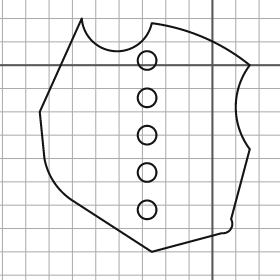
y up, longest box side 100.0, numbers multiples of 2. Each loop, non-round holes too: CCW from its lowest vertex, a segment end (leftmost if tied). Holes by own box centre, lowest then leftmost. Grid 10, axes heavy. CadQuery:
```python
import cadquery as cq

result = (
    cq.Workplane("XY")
    .moveTo(-26.0, -80.0)
    .lineTo(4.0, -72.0)
    .threePointArc((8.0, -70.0), (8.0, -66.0))
    .lineTo(16.0, -36.0)
    .threePointArc((10.0, -18.0), (16.0, 0.0))
    .threePointArc((-4.0, 12.0), (-26.0, 18.0))
    .threePointArc((-42.0, 6.0), (-56.0, 20.0))
    .lineTo(-74.0, -20.0)
    .lineTo(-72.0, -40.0)
    .threePointArc((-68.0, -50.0), (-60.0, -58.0))
    .close()
    .moveTo(-28.0, -62.0)
    .circle(4.0)
    .moveTo(-28.0, -46.0)
    .circle(4.0)
    .moveTo(-28.0, -30.0)
    .circle(4.0)
    .moveTo(-28.0, -14.0)
    .circle(4.0)
    .moveTo(-28.0, 2.0)
    .circle(4.0)
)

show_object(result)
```